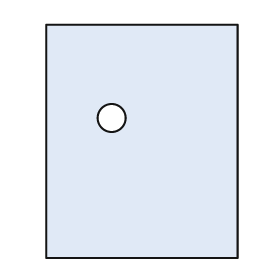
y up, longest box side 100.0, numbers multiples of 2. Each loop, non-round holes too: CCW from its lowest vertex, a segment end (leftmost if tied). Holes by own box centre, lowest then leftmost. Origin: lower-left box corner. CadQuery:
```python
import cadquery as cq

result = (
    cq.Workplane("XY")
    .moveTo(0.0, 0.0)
    .lineTo(82.0, 0.0)
    .lineTo(82.0, 100.0)
    .lineTo(0.0, 100.0)
    .close()
    .moveTo(28.0, 60.0)
    .circle(6.0)
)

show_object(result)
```